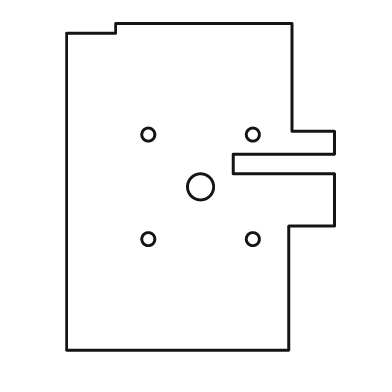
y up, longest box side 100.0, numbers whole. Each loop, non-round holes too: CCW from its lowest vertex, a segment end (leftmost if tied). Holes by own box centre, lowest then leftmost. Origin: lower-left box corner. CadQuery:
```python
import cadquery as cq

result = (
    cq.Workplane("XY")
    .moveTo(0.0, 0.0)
    .lineTo(68.0, 0.0)
    .lineTo(68.0, 38.0)
    .lineTo(82.0, 38.0)
    .lineTo(82.0, 54.0)
    .lineTo(51.0, 54.0)
    .lineTo(51.0, 60.0)
    .lineTo(82.0, 60.0)
    .lineTo(82.0, 67.0)
    .lineTo(69.0, 67.0)
    .lineTo(69.0, 100.0)
    .lineTo(15.0, 100.0)
    .lineTo(15.0, 97.0)
    .lineTo(0.0, 97.0)
    .close()
    .moveTo(25.0, 34.0)
    .circle(2.0)
    .moveTo(57.0, 34.0)
    .circle(2.0)
    .moveTo(41.0, 50.0)
    .circle(4.0)
    .moveTo(25.0, 66.0)
    .circle(2.0)
    .moveTo(57.0, 66.0)
    .circle(2.0)
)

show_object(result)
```